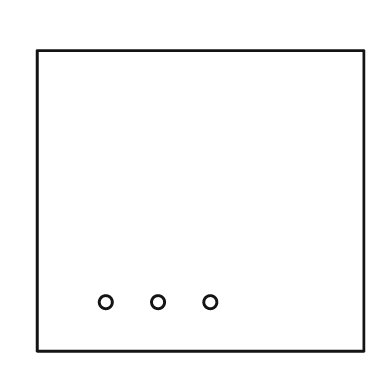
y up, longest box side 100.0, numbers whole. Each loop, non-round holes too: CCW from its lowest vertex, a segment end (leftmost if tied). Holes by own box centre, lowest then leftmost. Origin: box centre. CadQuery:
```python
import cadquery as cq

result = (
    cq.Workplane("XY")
    .moveTo(-50.0, -46.0)
    .lineTo(50.0, -46.0)
    .lineTo(50.0, 46.0)
    .lineTo(-50.0, 46.0)
    .close()
    .moveTo(-29.0, -31.0)
    .circle(2.0)
    .moveTo(-13.0, -31.0)
    .circle(2.0)
    .moveTo(3.0, -31.0)
    .circle(2.0)
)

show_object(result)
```